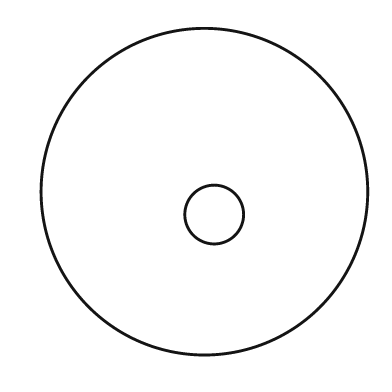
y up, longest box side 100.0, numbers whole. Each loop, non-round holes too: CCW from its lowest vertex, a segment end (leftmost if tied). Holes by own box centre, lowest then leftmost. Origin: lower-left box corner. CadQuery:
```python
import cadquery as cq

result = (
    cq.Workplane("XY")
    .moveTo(50.0, 50.0)
    .circle(50.0)
    .moveTo(53.0, 43.0)
    .circle(9.0)
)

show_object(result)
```